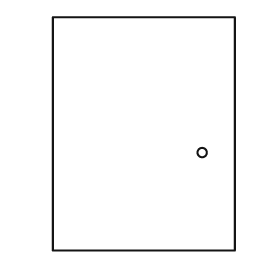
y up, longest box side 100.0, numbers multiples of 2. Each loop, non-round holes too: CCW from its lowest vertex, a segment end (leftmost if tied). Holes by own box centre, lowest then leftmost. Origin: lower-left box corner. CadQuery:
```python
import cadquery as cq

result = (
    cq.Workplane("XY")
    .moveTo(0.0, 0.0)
    .lineTo(78.0, 0.0)
    .lineTo(78.0, 100.0)
    .lineTo(0.0, 100.0)
    .close()
    .moveTo(64.0, 42.0)
    .circle(2.0)
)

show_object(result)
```